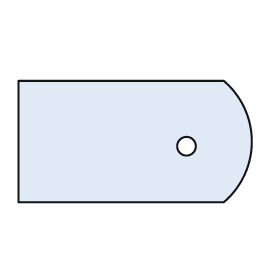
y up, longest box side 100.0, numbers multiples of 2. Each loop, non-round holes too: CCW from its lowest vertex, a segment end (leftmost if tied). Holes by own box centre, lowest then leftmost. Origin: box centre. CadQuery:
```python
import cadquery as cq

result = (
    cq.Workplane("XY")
    .moveTo(-50.0, -26.0)
    .lineTo(38.0, -26.0)
    .threePointArc((50.0, 0.0), (38.0, 26.0))
    .lineTo(-50.0, 26.0)
    .close()
    .moveTo(22.0, -2.0)
    .circle(4.0)
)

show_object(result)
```